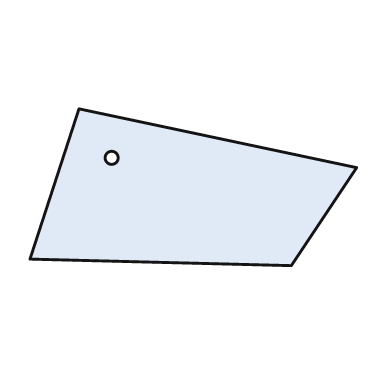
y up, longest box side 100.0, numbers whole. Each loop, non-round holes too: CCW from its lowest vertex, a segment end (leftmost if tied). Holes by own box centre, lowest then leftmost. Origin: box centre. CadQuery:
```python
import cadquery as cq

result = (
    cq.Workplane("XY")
    .moveTo(30.0, -24.0)
    .lineTo(50.0, 6.0)
    .lineTo(-35.0, 24.0)
    .lineTo(-50.0, -22.0)
    .close()
    .moveTo(-25.0, 9.0)
    .circle(2.0)
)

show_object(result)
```